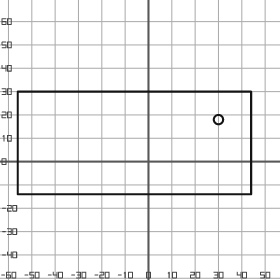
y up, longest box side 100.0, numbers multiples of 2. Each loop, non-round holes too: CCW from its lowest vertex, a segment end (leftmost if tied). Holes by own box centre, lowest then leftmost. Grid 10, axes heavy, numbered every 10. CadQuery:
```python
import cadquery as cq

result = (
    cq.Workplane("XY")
    .moveTo(-56.0, -14.0)
    .lineTo(44.0, -14.0)
    .lineTo(44.0, 30.0)
    .lineTo(-56.0, 30.0)
    .close()
    .moveTo(30.0, 18.0)
    .circle(2.0)
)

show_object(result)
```